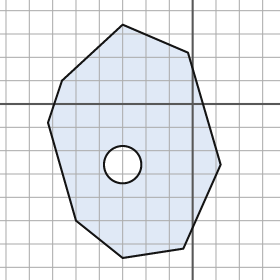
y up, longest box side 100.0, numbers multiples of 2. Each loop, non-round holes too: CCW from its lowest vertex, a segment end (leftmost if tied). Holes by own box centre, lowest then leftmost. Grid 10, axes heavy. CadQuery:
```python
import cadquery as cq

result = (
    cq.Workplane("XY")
    .moveTo(-30.0, -66.0)
    .lineTo(-4.0, -62.0)
    .lineTo(12.0, -26.0)
    .lineTo(-2.0, 22.0)
    .lineTo(-30.0, 34.0)
    .lineTo(-56.0, 10.0)
    .lineTo(-62.0, -8.0)
    .lineTo(-50.0, -50.0)
    .close()
    .moveTo(-30.0, -26.0)
    .circle(8.0)
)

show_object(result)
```